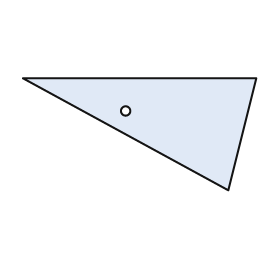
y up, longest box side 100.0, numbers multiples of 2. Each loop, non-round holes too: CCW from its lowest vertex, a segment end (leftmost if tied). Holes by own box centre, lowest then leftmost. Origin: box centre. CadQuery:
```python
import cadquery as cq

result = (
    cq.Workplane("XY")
    .moveTo(38.0, -24.0)
    .lineTo(50.0, 24.0)
    .lineTo(-50.0, 24.0)
    .close()
    .moveTo(-6.0, 10.0)
    .circle(2.0)
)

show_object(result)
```